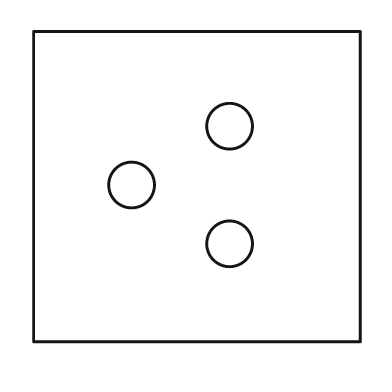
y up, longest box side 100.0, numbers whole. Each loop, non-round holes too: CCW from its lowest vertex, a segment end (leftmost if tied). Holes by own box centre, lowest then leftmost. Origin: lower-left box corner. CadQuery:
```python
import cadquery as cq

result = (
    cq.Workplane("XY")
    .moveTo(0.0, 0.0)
    .lineTo(100.0, 0.0)
    .lineTo(100.0, 95.0)
    .lineTo(0.0, 95.0)
    .close()
    .moveTo(60.0, 30.0)
    .circle(7.0)
    .moveTo(30.0, 48.0)
    .circle(7.0)
    .moveTo(60.0, 66.0)
    .circle(7.0)
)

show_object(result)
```